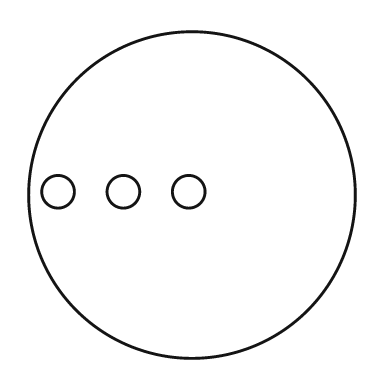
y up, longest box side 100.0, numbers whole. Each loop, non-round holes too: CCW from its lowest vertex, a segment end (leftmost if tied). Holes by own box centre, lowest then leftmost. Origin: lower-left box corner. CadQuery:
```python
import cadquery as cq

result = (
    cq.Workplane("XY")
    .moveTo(50.0, 50.0)
    .circle(50.0)
    .moveTo(9.0, 51.0)
    .circle(5.0)
    .moveTo(29.0, 51.0)
    .circle(5.0)
    .moveTo(49.0, 51.0)
    .circle(5.0)
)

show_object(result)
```